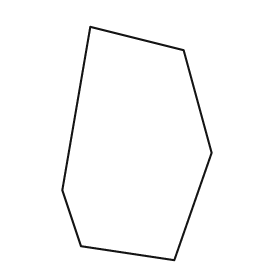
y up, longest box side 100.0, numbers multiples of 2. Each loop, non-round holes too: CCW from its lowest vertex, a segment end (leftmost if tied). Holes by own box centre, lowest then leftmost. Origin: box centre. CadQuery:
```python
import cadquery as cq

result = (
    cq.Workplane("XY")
    .moveTo(16.0, -50.0)
    .lineTo(32.0, -4.0)
    .lineTo(20.0, 40.0)
    .lineTo(-20.0, 50.0)
    .lineTo(-32.0, -20.0)
    .lineTo(-24.0, -44.0)
    .close()
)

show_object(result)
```